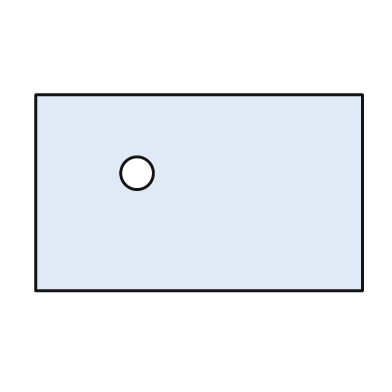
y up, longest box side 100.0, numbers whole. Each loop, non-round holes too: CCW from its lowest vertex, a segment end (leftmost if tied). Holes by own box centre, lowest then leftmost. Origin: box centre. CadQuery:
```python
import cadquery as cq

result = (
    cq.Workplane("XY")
    .moveTo(-50.0, -30.0)
    .lineTo(50.0, -30.0)
    .lineTo(50.0, 30.0)
    .lineTo(-50.0, 30.0)
    .close()
    .moveTo(-19.0, 6.0)
    .circle(5.0)
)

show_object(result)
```